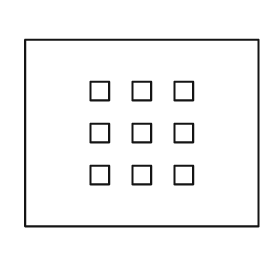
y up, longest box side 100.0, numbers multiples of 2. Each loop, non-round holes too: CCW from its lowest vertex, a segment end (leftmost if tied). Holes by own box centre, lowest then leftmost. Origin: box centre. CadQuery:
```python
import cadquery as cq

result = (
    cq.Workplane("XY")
    .moveTo(-50.0, -40.0)
    .lineTo(50.0, -40.0)
    .lineTo(50.0, 40.0)
    .lineTo(-50.0, 40.0)
    .close()
    .moveTo(-22.0, -22.0)
    .lineTo(-14.0, -22.0)
    .lineTo(-14.0, -14.0)
    .lineTo(-22.0, -14.0)
    .close()
    .moveTo(-4.0, -22.0)
    .lineTo(4.0, -22.0)
    .lineTo(4.0, -14.0)
    .lineTo(-4.0, -14.0)
    .close()
    .moveTo(14.0, -22.0)
    .lineTo(22.0, -22.0)
    .lineTo(22.0, -14.0)
    .lineTo(14.0, -14.0)
    .close()
    .moveTo(-22.0, -4.0)
    .lineTo(-14.0, -4.0)
    .lineTo(-14.0, 4.0)
    .lineTo(-22.0, 4.0)
    .close()
    .moveTo(-4.0, -4.0)
    .lineTo(4.0, -4.0)
    .lineTo(4.0, 4.0)
    .lineTo(-4.0, 4.0)
    .close()
    .moveTo(14.0, -4.0)
    .lineTo(22.0, -4.0)
    .lineTo(22.0, 4.0)
    .lineTo(14.0, 4.0)
    .close()
    .moveTo(-22.0, 14.0)
    .lineTo(-14.0, 14.0)
    .lineTo(-14.0, 22.0)
    .lineTo(-22.0, 22.0)
    .close()
    .moveTo(-4.0, 14.0)
    .lineTo(4.0, 14.0)
    .lineTo(4.0, 22.0)
    .lineTo(-4.0, 22.0)
    .close()
    .moveTo(14.0, 14.0)
    .lineTo(22.0, 14.0)
    .lineTo(22.0, 22.0)
    .lineTo(14.0, 22.0)
    .close()
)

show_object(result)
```